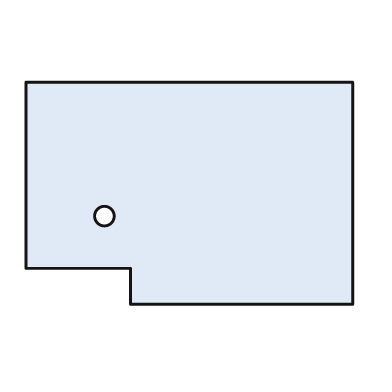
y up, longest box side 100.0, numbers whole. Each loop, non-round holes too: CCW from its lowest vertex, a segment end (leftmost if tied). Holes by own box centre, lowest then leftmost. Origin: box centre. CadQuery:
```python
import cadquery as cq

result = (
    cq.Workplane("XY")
    .moveTo(-18.0, -34.0)
    .lineTo(50.0, -34.0)
    .lineTo(50.0, 34.0)
    .lineTo(-50.0, 34.0)
    .lineTo(-50.0, -23.0)
    .lineTo(-18.0, -23.0)
    .close()
    .moveTo(-26.0, -7.0)
    .circle(3.0)
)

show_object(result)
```